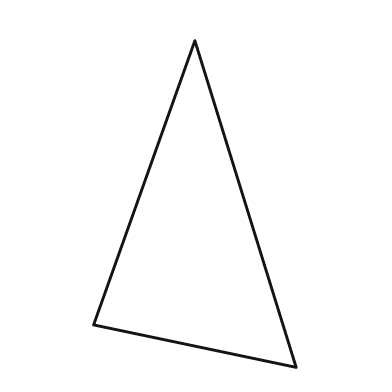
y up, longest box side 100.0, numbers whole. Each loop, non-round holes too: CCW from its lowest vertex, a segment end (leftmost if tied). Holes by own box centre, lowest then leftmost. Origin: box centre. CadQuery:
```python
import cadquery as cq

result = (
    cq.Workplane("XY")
    .moveTo(31.0, -50.0)
    .lineTo(0.0, 50.0)
    .lineTo(-31.0, -37.0)
    .close()
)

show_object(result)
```